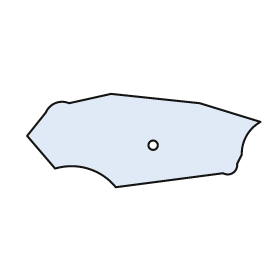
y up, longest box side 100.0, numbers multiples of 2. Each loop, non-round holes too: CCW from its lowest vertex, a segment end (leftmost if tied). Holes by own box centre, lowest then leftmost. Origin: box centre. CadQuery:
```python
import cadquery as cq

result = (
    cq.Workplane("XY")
    .moveTo(-12.0, -20.0)
    .lineTo(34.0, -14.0)
    .threePointArc((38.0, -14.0), (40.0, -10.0))
    .lineTo(42.0, -6.0)
    .threePointArc((44.0, 2.0), (50.0, 8.0))
    .lineTo(24.0, 16.0)
    .lineTo(-14.0, 20.0)
    .lineTo(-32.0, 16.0)
    .threePointArc((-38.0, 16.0), (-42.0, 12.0))
    .lineTo(-50.0, 2.0)
    .lineTo(-38.0, -12.0)
    .threePointArc((-24.0, -12.0), (-12.0, -20.0))
    .close()
    .moveTo(4.0, -2.0)
    .circle(2.0)
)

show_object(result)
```